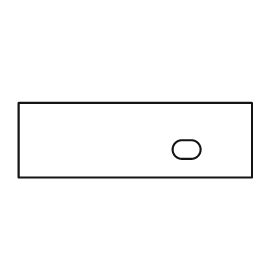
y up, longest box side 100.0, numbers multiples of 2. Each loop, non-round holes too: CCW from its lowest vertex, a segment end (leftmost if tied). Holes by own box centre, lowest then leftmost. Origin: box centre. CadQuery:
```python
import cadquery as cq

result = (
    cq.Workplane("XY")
    .moveTo(-50.0, -16.0)
    .lineTo(50.0, -16.0)
    .lineTo(50.0, 16.0)
    .lineTo(-50.0, 16.0)
    .close()
    .moveTo(20.0, -8.0)
    .lineTo(24.0, -8.0)
    .threePointArc((28.0, -4.0), (24.0, 0.0))
    .lineTo(20.0, 0.0)
    .threePointArc((16.0, -4.0), (20.0, -8.0))
    .close()
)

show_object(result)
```